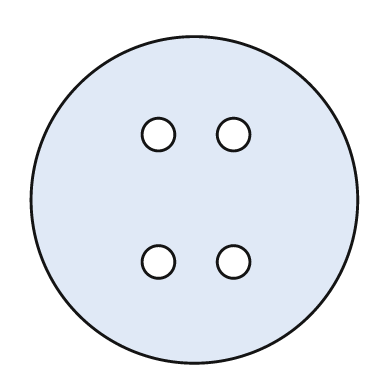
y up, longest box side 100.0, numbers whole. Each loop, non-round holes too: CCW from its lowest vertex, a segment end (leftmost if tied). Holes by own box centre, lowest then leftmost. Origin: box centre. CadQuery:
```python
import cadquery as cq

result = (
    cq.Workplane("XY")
    .moveTo(0.0, 0.0)
    .circle(50.0)
    .moveTo(-11.0, -19.0)
    .circle(5.0)
    .moveTo(12.0, -19.0)
    .circle(5.0)
    .moveTo(-11.0, 20.0)
    .circle(5.0)
    .moveTo(12.0, 20.0)
    .circle(5.0)
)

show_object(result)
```